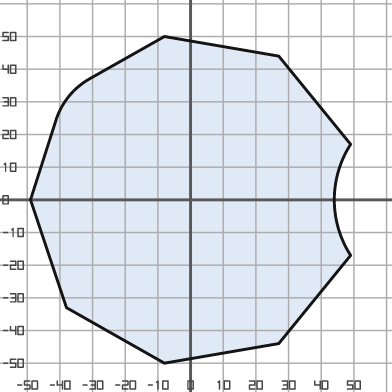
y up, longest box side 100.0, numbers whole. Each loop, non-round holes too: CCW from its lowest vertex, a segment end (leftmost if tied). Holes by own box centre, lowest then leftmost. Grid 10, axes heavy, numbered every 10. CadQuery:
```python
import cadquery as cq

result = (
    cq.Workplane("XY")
    .moveTo(-8.0, -50.0)
    .lineTo(27.0, -44.0)
    .lineTo(49.0, -17.0)
    .threePointArc((44.0, 0.0), (49.0, 17.0))
    .lineTo(27.0, 44.0)
    .lineTo(-8.0, 50.0)
    .lineTo(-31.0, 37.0)
    .threePointArc((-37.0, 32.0), (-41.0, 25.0))
    .lineTo(-49.0, 0.0)
    .lineTo(-38.0, -33.0)
    .close()
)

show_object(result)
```